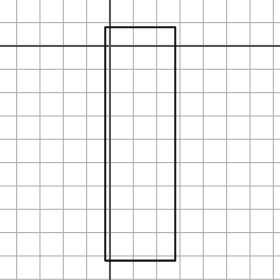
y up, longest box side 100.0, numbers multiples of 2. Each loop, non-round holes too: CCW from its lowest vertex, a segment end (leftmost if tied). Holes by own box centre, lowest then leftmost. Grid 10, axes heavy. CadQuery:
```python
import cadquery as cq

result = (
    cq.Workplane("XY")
    .moveTo(-2.0, -92.0)
    .lineTo(28.0, -92.0)
    .lineTo(28.0, 8.0)
    .lineTo(-2.0, 8.0)
    .close()
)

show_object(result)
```